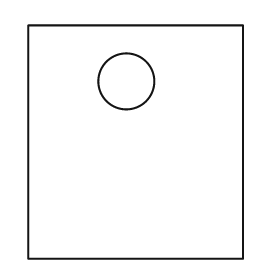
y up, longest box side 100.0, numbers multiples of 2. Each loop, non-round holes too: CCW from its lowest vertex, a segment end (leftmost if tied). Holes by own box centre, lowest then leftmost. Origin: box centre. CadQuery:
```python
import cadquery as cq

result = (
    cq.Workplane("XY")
    .moveTo(-46.0, -50.0)
    .lineTo(46.0, -50.0)
    .lineTo(46.0, 50.0)
    .lineTo(-46.0, 50.0)
    .close()
    .moveTo(-4.0, 26.0)
    .circle(12.0)
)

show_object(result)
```